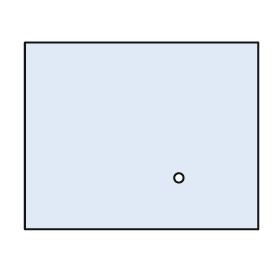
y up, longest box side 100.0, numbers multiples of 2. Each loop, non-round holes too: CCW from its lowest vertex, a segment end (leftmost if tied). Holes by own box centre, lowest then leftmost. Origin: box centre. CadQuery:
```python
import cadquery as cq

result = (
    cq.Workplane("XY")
    .moveTo(-50.0, -40.0)
    .lineTo(50.0, -40.0)
    .lineTo(50.0, 40.0)
    .lineTo(-50.0, 40.0)
    .close()
    .moveTo(16.0, -18.0)
    .circle(2.0)
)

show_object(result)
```